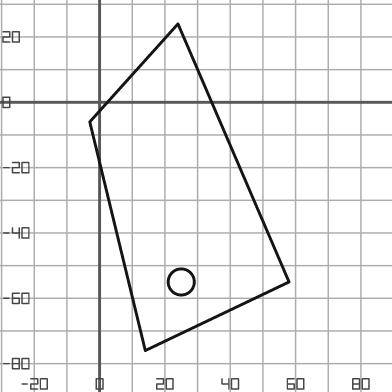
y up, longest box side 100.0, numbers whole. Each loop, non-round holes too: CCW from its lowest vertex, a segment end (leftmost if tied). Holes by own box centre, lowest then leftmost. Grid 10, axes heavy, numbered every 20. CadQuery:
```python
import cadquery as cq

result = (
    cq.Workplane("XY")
    .moveTo(14.0, -76.0)
    .lineTo(58.0, -55.0)
    .lineTo(24.0, 24.0)
    .lineTo(-3.0, -6.0)
    .close()
    .moveTo(25.0, -55.0)
    .circle(4.0)
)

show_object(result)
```